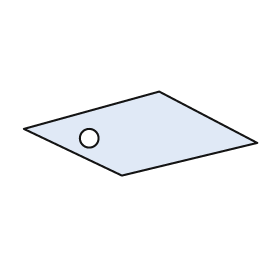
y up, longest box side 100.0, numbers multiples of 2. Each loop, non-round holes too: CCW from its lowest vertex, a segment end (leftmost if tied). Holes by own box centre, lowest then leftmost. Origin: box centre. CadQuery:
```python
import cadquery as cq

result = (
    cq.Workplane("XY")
    .moveTo(-8.0, -18.0)
    .lineTo(50.0, -4.0)
    .lineTo(8.0, 18.0)
    .lineTo(-50.0, 2.0)
    .close()
    .moveTo(-22.0, -2.0)
    .circle(4.0)
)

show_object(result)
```